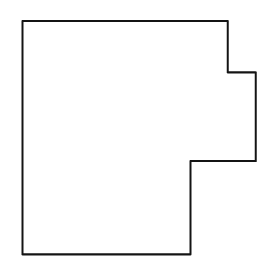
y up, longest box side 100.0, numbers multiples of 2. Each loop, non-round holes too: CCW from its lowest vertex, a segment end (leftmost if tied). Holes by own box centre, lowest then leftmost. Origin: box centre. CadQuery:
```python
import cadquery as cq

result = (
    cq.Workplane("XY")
    .moveTo(-50.0, -50.0)
    .lineTo(22.0, -50.0)
    .lineTo(22.0, -10.0)
    .lineTo(50.0, -10.0)
    .lineTo(50.0, 28.0)
    .lineTo(38.0, 28.0)
    .lineTo(38.0, 50.0)
    .lineTo(-50.0, 50.0)
    .close()
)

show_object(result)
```